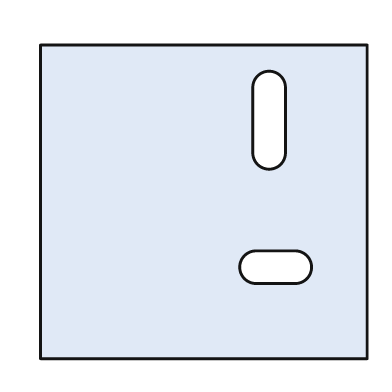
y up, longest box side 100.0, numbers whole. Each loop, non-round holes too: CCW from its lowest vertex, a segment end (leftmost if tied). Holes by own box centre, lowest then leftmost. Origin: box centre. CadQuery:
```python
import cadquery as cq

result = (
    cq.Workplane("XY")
    .moveTo(-50.0, -48.0)
    .lineTo(50.0, -48.0)
    .lineTo(50.0, 48.0)
    .lineTo(-50.0, 48.0)
    .close()
    .moveTo(16.0, -25.0)
    .lineTo(28.0, -25.0)
    .threePointArc((33.0, -20.0), (28.0, -15.0))
    .lineTo(16.0, -15.0)
    .threePointArc((11.0, -20.0), (16.0, -25.0))
    .close()
    .moveTo(15.0, 15.0)
    .threePointArc((20.0, 10.0), (25.0, 15.0))
    .lineTo(25.0, 35.0)
    .threePointArc((20.0, 40.0), (15.0, 35.0))
    .close()
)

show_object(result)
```